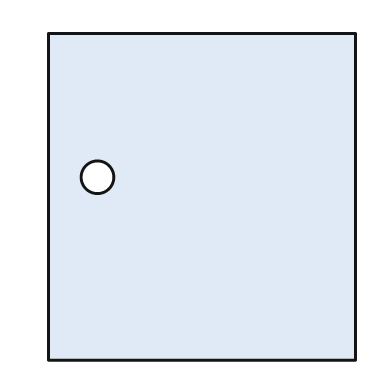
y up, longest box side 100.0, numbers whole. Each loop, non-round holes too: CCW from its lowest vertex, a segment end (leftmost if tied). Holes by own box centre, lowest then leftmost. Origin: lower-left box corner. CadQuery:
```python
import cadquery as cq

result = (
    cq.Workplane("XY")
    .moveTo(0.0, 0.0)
    .lineTo(94.0, 0.0)
    .lineTo(94.0, 100.0)
    .lineTo(0.0, 100.0)
    .close()
    .moveTo(15.0, 56.0)
    .circle(5.0)
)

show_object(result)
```